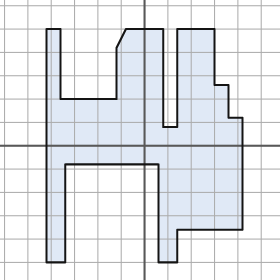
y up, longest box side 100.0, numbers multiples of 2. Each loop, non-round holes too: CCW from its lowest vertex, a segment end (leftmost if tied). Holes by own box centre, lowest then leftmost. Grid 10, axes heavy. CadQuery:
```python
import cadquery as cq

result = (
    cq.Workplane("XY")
    .moveTo(-42.0, -50.0)
    .lineTo(-34.0, -50.0)
    .lineTo(-34.0, -8.0)
    .lineTo(6.0, -8.0)
    .lineTo(6.0, -50.0)
    .lineTo(14.0, -50.0)
    .lineTo(14.0, -36.0)
    .lineTo(42.0, -36.0)
    .lineTo(42.0, 12.0)
    .lineTo(36.0, 12.0)
    .lineTo(36.0, 26.0)
    .lineTo(30.0, 26.0)
    .lineTo(30.0, 50.0)
    .lineTo(14.0, 50.0)
    .lineTo(14.0, 8.0)
    .lineTo(8.0, 8.0)
    .lineTo(8.0, 50.0)
    .lineTo(-8.0, 50.0)
    .lineTo(-12.0, 42.0)
    .lineTo(-12.0, 20.0)
    .lineTo(-36.0, 20.0)
    .lineTo(-36.0, 50.0)
    .lineTo(-42.0, 50.0)
    .close()
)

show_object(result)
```